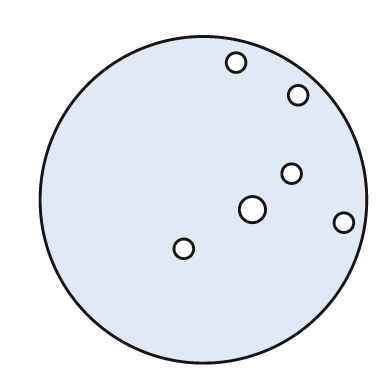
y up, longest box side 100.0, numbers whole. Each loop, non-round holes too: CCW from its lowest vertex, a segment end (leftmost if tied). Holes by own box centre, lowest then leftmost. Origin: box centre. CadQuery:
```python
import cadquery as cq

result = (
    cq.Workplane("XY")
    .moveTo(0.0, 0.0)
    .circle(50.0)
    .moveTo(-6.0, -15.0)
    .circle(3.0)
    .moveTo(43.0, -7.0)
    .circle(3.0)
    .moveTo(15.0, -3.0)
    .circle(4.0)
    .moveTo(27.0, 8.0)
    .circle(3.0)
    .moveTo(29.0, 32.0)
    .circle(3.0)
    .moveTo(10.0, 42.0)
    .circle(3.0)
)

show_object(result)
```